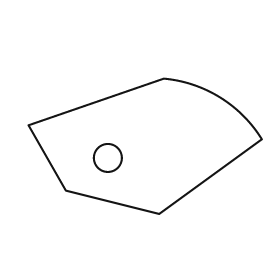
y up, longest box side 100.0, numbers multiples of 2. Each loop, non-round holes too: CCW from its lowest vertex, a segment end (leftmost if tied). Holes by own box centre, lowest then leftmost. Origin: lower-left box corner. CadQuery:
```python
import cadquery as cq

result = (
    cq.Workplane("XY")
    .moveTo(56.0, 0.0)
    .lineTo(100.0, 32.0)
    .threePointArc((82.0, 50.0), (58.0, 58.0))
    .lineTo(0.0, 38.0)
    .lineTo(16.0, 10.0)
    .close()
    .moveTo(34.0, 24.0)
    .circle(6.0)
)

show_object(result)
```